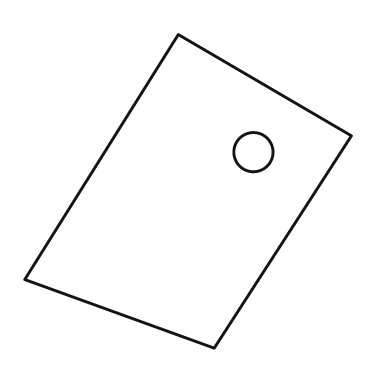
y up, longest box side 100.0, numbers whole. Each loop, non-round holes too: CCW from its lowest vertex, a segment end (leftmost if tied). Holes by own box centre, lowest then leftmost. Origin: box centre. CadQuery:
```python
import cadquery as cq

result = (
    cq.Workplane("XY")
    .moveTo(8.0, -48.0)
    .lineTo(50.0, 17.0)
    .lineTo(-3.0, 48.0)
    .lineTo(-50.0, -27.0)
    .close()
    .moveTo(20.0, 12.0)
    .circle(6.0)
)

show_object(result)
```